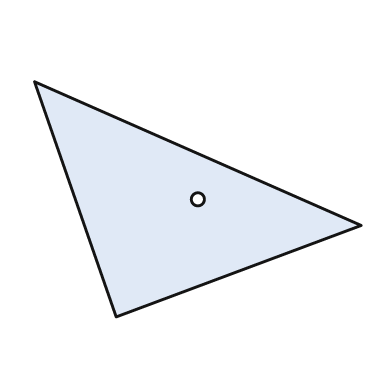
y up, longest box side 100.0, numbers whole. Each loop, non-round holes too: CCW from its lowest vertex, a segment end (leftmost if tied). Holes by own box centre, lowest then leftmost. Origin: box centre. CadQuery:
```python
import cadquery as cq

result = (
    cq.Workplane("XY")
    .moveTo(-25.0, -36.0)
    .lineTo(50.0, -8.0)
    .lineTo(-50.0, 36.0)
    .close()
    .moveTo(0.0, 0.0)
    .circle(2.0)
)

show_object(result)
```